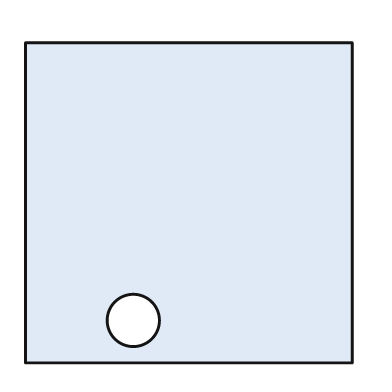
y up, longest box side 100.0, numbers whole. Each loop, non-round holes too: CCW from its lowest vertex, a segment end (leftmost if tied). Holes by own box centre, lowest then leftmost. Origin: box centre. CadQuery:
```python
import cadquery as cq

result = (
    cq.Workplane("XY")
    .moveTo(-50.0, -49.0)
    .lineTo(50.0, -49.0)
    .lineTo(50.0, 49.0)
    .lineTo(-50.0, 49.0)
    .close()
    .moveTo(-17.0, -36.0)
    .circle(8.0)
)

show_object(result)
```